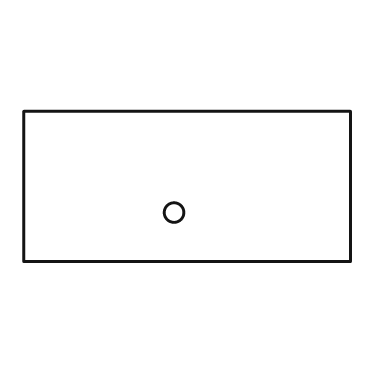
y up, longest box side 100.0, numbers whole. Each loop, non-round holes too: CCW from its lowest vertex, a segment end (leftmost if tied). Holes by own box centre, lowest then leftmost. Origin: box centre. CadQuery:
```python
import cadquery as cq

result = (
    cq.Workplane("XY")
    .moveTo(-50.0, -23.0)
    .lineTo(50.0, -23.0)
    .lineTo(50.0, 23.0)
    .lineTo(-50.0, 23.0)
    .close()
    .moveTo(-4.0, -8.0)
    .circle(3.0)
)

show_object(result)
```